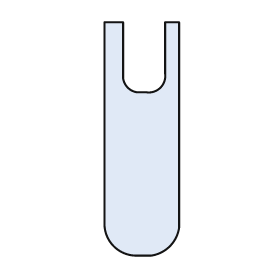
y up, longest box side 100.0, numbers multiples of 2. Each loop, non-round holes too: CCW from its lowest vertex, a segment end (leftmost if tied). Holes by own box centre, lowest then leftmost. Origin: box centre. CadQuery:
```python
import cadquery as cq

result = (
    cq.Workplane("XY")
    .moveTo(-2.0, -50.0)
    .lineTo(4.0, -50.0)
    .threePointArc((12.0, -46.0), (16.0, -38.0))
    .lineTo(16.0, 50.0)
    .lineTo(10.0, 50.0)
    .lineTo(10.0, 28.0)
    .threePointArc((8.0, 22.0), (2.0, 20.0))
    .lineTo(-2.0, 20.0)
    .threePointArc((-6.0, 22.0), (-8.0, 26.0))
    .lineTo(-8.0, 50.0)
    .lineTo(-16.0, 50.0)
    .lineTo(-16.0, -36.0)
    .threePointArc((-12.0, -46.0), (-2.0, -50.0))
    .close()
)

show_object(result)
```